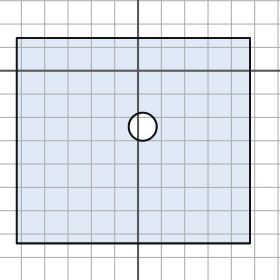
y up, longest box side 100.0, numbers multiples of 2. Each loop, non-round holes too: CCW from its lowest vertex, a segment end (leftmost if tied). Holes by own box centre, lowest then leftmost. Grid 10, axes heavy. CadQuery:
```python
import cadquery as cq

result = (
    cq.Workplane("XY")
    .moveTo(-52.0, -74.0)
    .lineTo(48.0, -74.0)
    .lineTo(48.0, 14.0)
    .lineTo(-52.0, 14.0)
    .close()
    .moveTo(2.0, -24.0)
    .circle(6.0)
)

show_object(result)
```